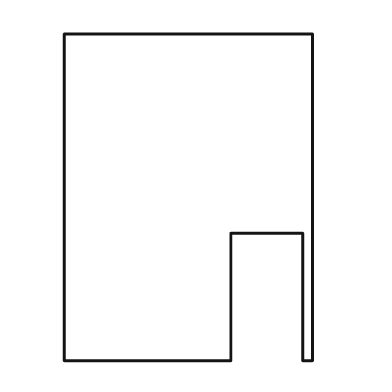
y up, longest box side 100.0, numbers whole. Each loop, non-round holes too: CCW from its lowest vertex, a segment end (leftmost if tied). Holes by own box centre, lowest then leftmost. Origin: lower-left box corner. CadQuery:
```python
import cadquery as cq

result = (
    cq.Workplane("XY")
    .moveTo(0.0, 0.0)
    .lineTo(51.0, 0.0)
    .lineTo(51.0, 39.0)
    .lineTo(73.0, 39.0)
    .lineTo(73.0, 0.0)
    .lineTo(76.0, 0.0)
    .lineTo(76.0, 100.0)
    .lineTo(0.0, 100.0)
    .close()
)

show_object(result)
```